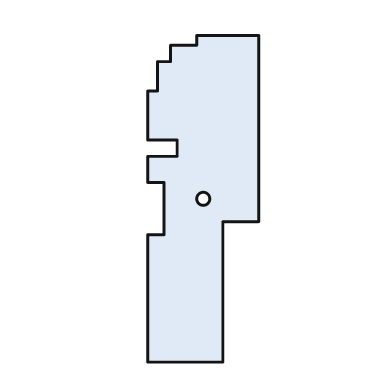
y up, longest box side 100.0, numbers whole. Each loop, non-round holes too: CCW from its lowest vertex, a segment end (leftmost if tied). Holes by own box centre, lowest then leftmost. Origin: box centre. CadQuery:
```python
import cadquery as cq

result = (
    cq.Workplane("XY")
    .moveTo(-17.0, -50.0)
    .lineTo(6.0, -50.0)
    .lineTo(6.0, -7.0)
    .lineTo(17.0, -7.0)
    .lineTo(17.0, 50.0)
    .lineTo(-2.0, 50.0)
    .lineTo(-2.0, 47.0)
    .lineTo(-10.0, 47.0)
    .lineTo(-10.0, 42.0)
    .lineTo(-14.0, 42.0)
    .lineTo(-14.0, 33.0)
    .lineTo(-17.0, 33.0)
    .lineTo(-17.0, 18.0)
    .lineTo(-8.0, 18.0)
    .lineTo(-8.0, 13.0)
    .lineTo(-17.0, 13.0)
    .lineTo(-17.0, 5.0)
    .lineTo(-12.0, 5.0)
    .lineTo(-12.0, -11.0)
    .lineTo(-17.0, -11.0)
    .close()
    .moveTo(0.0, 0.0)
    .circle(2.0)
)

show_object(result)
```